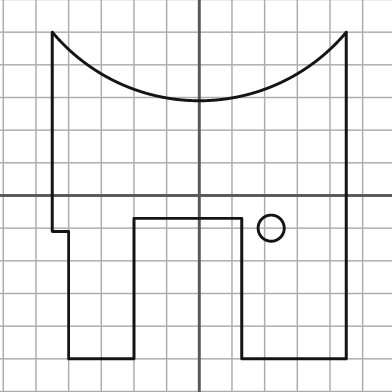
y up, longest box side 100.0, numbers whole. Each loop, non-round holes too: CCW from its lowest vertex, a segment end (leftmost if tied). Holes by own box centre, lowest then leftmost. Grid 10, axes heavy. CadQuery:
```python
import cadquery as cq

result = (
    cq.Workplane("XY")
    .moveTo(-40.0, -50.0)
    .lineTo(-20.0, -50.0)
    .lineTo(-20.0, -7.0)
    .lineTo(13.0, -7.0)
    .lineTo(13.0, -50.0)
    .lineTo(45.0, -50.0)
    .lineTo(45.0, 50.0)
    .threePointArc((0.0, 29.0), (-45.0, 50.0))
    .lineTo(-45.0, -11.0)
    .lineTo(-40.0, -11.0)
    .close()
    .moveTo(22.0, -10.0)
    .circle(4.0)
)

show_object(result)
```